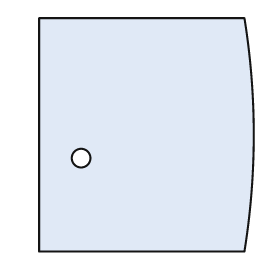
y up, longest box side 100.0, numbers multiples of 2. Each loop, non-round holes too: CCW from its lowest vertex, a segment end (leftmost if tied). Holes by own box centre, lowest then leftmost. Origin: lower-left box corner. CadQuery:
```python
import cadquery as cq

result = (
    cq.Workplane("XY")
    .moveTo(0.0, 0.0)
    .lineTo(88.0, 0.0)
    .threePointArc((92.0, 50.0), (88.0, 100.0))
    .lineTo(0.0, 100.0)
    .close()
    .moveTo(18.0, 40.0)
    .circle(4.0)
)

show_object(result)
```